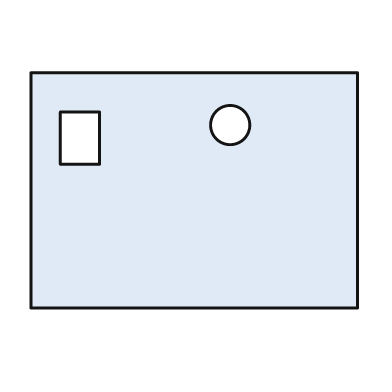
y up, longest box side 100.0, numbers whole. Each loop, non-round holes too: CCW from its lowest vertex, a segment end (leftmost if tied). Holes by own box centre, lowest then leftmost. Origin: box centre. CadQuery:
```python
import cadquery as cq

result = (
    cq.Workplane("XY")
    .moveTo(-50.0, -36.0)
    .lineTo(50.0, -36.0)
    .lineTo(50.0, 36.0)
    .lineTo(-50.0, 36.0)
    .close()
    .moveTo(-41.0, 8.0)
    .lineTo(-29.0, 8.0)
    .lineTo(-29.0, 24.0)
    .lineTo(-41.0, 24.0)
    .close()
    .moveTo(11.0, 20.0)
    .circle(6.0)
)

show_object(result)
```